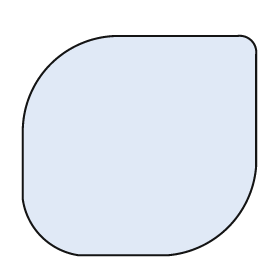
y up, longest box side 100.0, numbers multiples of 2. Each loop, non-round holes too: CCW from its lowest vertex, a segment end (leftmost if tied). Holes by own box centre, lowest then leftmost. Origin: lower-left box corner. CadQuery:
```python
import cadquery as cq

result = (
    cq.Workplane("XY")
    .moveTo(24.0, 0.0)
    .lineTo(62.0, 0.0)
    .threePointArc((88.0, 12.0), (100.0, 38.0))
    .lineTo(100.0, 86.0)
    .threePointArc((98.0, 92.0), (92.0, 94.0))
    .lineTo(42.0, 94.0)
    .threePointArc((12.0, 82.0), (0.0, 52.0))
    .lineTo(0.0, 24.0)
    .threePointArc((8.0, 8.0), (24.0, 0.0))
    .close()
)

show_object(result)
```